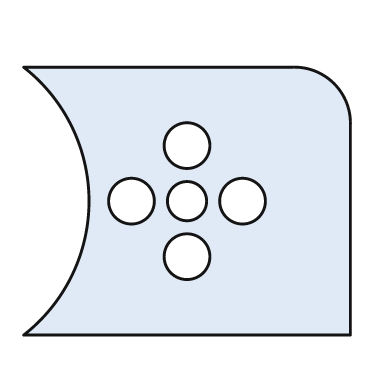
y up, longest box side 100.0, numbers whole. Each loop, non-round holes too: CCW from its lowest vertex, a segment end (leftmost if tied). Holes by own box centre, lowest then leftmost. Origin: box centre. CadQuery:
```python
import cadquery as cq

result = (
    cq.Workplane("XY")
    .moveTo(-50.0, -41.0)
    .lineTo(50.0, -41.0)
    .lineTo(50.0, 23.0)
    .threePointArc((45.0, 36.0), (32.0, 41.0))
    .lineTo(-50.0, 41.0)
    .threePointArc((-30.0, 0.0), (-50.0, -41.0))
    .close()
    .moveTo(0.0, -17.0)
    .circle(7.0)
    .moveTo(-17.0, 0.0)
    .circle(7.0)
    .moveTo(0.0, 0.0)
    .circle(6.0)
    .moveTo(17.0, 0.0)
    .circle(7.0)
    .moveTo(0.0, 17.0)
    .circle(7.0)
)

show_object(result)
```